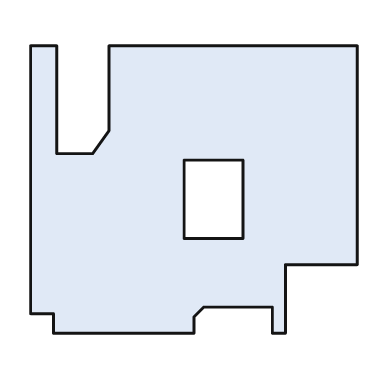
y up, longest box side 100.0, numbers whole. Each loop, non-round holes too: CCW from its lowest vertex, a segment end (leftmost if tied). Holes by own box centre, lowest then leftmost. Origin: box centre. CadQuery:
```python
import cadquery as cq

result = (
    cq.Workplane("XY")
    .moveTo(-43.0, -44.0)
    .lineTo(0.0, -44.0)
    .lineTo(0.0, -39.0)
    .lineTo(3.0, -36.0)
    .lineTo(24.0, -36.0)
    .lineTo(24.0, -44.0)
    .lineTo(28.0, -44.0)
    .lineTo(28.0, -23.0)
    .lineTo(50.0, -23.0)
    .lineTo(50.0, 44.0)
    .lineTo(-26.0, 44.0)
    .lineTo(-26.0, 18.0)
    .lineTo(-31.0, 11.0)
    .lineTo(-42.0, 11.0)
    .lineTo(-42.0, 44.0)
    .lineTo(-50.0, 44.0)
    .lineTo(-50.0, -38.0)
    .lineTo(-43.0, -38.0)
    .close()
    .moveTo(-3.0, -15.0)
    .lineTo(15.0, -15.0)
    .lineTo(15.0, 9.0)
    .lineTo(-3.0, 9.0)
    .close()
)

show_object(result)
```